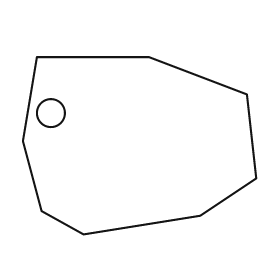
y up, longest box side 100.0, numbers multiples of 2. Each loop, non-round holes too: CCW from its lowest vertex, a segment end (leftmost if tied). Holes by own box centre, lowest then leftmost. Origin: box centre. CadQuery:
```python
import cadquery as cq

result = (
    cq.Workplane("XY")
    .moveTo(-24.0, -38.0)
    .lineTo(26.0, -30.0)
    .lineTo(50.0, -14.0)
    .lineTo(46.0, 22.0)
    .lineTo(4.0, 38.0)
    .lineTo(-44.0, 38.0)
    .lineTo(-50.0, 2.0)
    .lineTo(-42.0, -28.0)
    .close()
    .moveTo(-38.0, 14.0)
    .circle(6.0)
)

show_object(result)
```